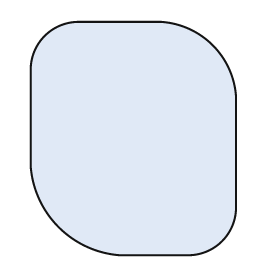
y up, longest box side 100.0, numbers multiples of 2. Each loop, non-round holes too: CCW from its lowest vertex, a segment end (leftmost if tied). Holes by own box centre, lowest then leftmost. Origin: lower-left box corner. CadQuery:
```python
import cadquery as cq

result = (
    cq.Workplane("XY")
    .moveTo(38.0, 0.0)
    .lineTo(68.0, 0.0)
    .threePointArc((82.0, 6.0), (88.0, 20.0))
    .lineTo(88.0, 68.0)
    .threePointArc((78.0, 90.0), (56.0, 100.0))
    .lineTo(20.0, 100.0)
    .threePointArc((6.0, 94.0), (0.0, 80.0))
    .lineTo(0.0, 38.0)
    .threePointArc((12.0, 12.0), (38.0, 0.0))
    .close()
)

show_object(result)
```